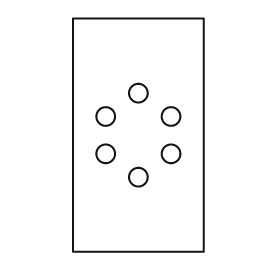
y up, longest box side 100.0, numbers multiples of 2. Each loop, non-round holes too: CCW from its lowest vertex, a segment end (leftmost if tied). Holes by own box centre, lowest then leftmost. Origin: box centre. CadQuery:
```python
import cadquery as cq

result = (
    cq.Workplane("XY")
    .moveTo(-28.0, -50.0)
    .lineTo(28.0, -50.0)
    .lineTo(28.0, 50.0)
    .lineTo(-28.0, 50.0)
    .close()
    .moveTo(0.0, -18.0)
    .circle(4.0)
    .moveTo(-14.0, -8.0)
    .circle(4.0)
    .moveTo(14.0, -8.0)
    .circle(4.0)
    .moveTo(-14.0, 8.0)
    .circle(4.0)
    .moveTo(14.0, 8.0)
    .circle(4.0)
    .moveTo(0.0, 18.0)
    .circle(4.0)
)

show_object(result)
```